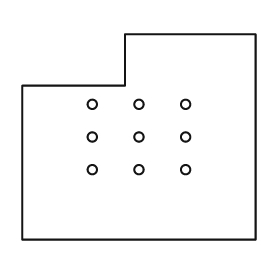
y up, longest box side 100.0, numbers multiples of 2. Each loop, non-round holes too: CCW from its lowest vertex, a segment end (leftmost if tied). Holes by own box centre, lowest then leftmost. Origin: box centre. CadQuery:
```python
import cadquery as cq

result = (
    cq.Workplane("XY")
    .moveTo(-50.0, -44.0)
    .lineTo(50.0, -44.0)
    .lineTo(50.0, 44.0)
    .lineTo(-6.0, 44.0)
    .lineTo(-6.0, 22.0)
    .lineTo(-50.0, 22.0)
    .close()
    .moveTo(-20.0, -14.0)
    .circle(2.0)
    .moveTo(0.0, -14.0)
    .circle(2.0)
    .moveTo(20.0, -14.0)
    .circle(2.0)
    .moveTo(-20.0, 0.0)
    .circle(2.0)
    .moveTo(0.0, 0.0)
    .circle(2.0)
    .moveTo(20.0, 0.0)
    .circle(2.0)
    .moveTo(-20.0, 14.0)
    .circle(2.0)
    .moveTo(0.0, 14.0)
    .circle(2.0)
    .moveTo(20.0, 14.0)
    .circle(2.0)
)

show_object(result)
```